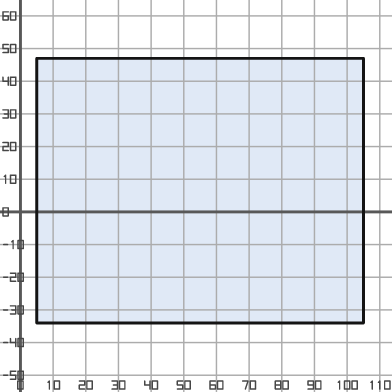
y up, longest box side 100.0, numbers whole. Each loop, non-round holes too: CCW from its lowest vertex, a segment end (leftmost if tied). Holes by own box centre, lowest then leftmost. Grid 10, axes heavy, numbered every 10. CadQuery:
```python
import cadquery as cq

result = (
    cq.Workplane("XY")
    .moveTo(5.0, -34.0)
    .lineTo(105.0, -34.0)
    .lineTo(105.0, 47.0)
    .lineTo(5.0, 47.0)
    .close()
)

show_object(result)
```